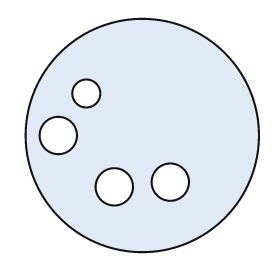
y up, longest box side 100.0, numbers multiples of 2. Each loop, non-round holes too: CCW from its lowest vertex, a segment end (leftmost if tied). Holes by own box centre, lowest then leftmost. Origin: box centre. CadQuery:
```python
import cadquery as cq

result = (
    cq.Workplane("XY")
    .moveTo(0.0, 0.0)
    .circle(50.0)
    .moveTo(-12.0, -22.0)
    .circle(8.0)
    .moveTo(12.0, -20.0)
    .circle(8.0)
    .moveTo(-36.0, 0.0)
    .circle(8.0)
    .moveTo(-24.0, 18.0)
    .circle(6.0)
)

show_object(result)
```